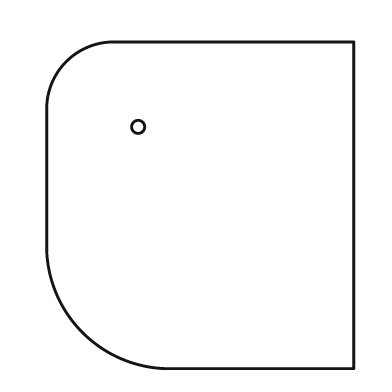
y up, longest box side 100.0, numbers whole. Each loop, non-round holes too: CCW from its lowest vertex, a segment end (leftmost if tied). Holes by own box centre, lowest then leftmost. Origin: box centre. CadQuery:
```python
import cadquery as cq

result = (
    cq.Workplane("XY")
    .moveTo(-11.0, -50.0)
    .lineTo(47.0, -50.0)
    .lineTo(47.0, 50.0)
    .lineTo(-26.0, 50.0)
    .threePointArc((-41.0, 44.0), (-47.0, 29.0))
    .lineTo(-47.0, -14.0)
    .threePointArc((-36.0, -39.0), (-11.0, -50.0))
    .close()
    .moveTo(-19.0, 24.0)
    .circle(2.0)
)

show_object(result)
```